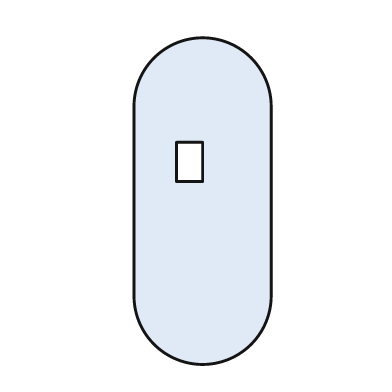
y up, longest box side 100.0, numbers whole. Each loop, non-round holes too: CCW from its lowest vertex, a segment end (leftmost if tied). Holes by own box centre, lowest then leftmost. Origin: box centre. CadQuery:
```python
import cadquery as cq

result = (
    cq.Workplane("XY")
    .moveTo(-21.0, -29.0)
    .threePointArc((0.0, -50.0), (21.0, -29.0))
    .lineTo(21.0, 29.0)
    .threePointArc((0.0, 50.0), (-21.0, 29.0))
    .close()
    .moveTo(-8.0, 6.0)
    .lineTo(0.0, 6.0)
    .lineTo(0.0, 18.0)
    .lineTo(-8.0, 18.0)
    .close()
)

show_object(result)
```